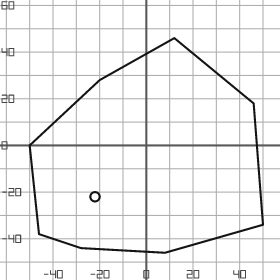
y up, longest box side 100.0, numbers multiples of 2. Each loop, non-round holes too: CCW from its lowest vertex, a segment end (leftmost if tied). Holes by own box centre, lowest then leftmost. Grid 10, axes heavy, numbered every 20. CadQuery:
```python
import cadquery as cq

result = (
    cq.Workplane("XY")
    .moveTo(8.0, -46.0)
    .lineTo(50.0, -34.0)
    .lineTo(46.0, 18.0)
    .lineTo(12.0, 46.0)
    .lineTo(-20.0, 28.0)
    .lineTo(-50.0, 0.0)
    .lineTo(-46.0, -38.0)
    .lineTo(-28.0, -44.0)
    .close()
    .moveTo(-22.0, -22.0)
    .circle(2.0)
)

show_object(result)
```